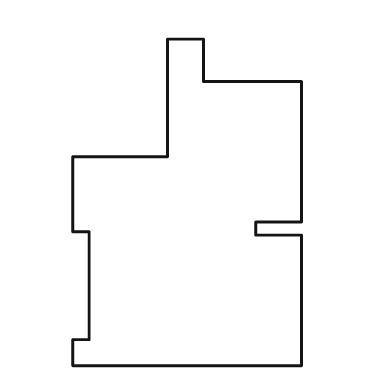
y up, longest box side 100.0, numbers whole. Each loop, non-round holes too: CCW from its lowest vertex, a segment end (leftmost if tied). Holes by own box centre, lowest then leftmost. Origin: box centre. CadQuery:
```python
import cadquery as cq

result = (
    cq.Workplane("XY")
    .moveTo(-35.0, -50.0)
    .lineTo(35.0, -50.0)
    .lineTo(35.0, -10.0)
    .lineTo(21.0, -10.0)
    .lineTo(21.0, -6.0)
    .lineTo(35.0, -6.0)
    .lineTo(35.0, 37.0)
    .lineTo(5.0, 37.0)
    .lineTo(5.0, 50.0)
    .lineTo(-6.0, 50.0)
    .lineTo(-6.0, 14.0)
    .lineTo(-35.0, 14.0)
    .lineTo(-35.0, -9.0)
    .lineTo(-30.0, -9.0)
    .lineTo(-30.0, -42.0)
    .lineTo(-35.0, -42.0)
    .close()
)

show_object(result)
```